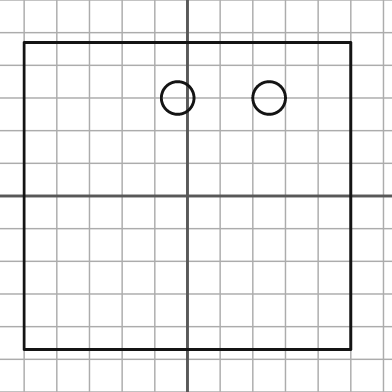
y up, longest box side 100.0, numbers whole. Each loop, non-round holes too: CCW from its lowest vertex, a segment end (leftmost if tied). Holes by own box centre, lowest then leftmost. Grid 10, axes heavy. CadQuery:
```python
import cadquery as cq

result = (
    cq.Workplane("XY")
    .moveTo(-50.0, -47.0)
    .lineTo(50.0, -47.0)
    .lineTo(50.0, 47.0)
    .lineTo(-50.0, 47.0)
    .close()
    .moveTo(-3.0, 30.0)
    .circle(5.0)
    .moveTo(25.0, 30.0)
    .circle(5.0)
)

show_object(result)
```